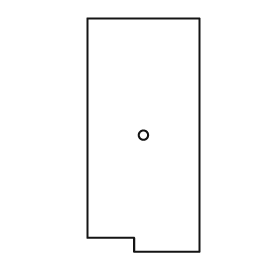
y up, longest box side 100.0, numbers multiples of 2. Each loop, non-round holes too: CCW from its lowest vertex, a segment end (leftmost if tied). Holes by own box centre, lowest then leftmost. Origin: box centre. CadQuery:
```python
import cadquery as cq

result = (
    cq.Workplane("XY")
    .moveTo(-4.0, -50.0)
    .lineTo(24.0, -50.0)
    .lineTo(24.0, 50.0)
    .lineTo(-24.0, 50.0)
    .lineTo(-24.0, -44.0)
    .lineTo(-4.0, -44.0)
    .close()
    .moveTo(0.0, 0.0)
    .circle(2.0)
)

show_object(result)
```